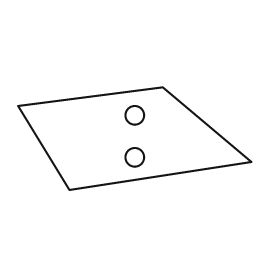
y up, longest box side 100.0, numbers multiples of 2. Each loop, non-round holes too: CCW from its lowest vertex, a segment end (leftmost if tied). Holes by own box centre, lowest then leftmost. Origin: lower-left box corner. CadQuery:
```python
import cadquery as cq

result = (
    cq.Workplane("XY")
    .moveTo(22.0, 0.0)
    .lineTo(100.0, 12.0)
    .lineTo(62.0, 44.0)
    .lineTo(0.0, 36.0)
    .close()
    .moveTo(50.0, 14.0)
    .circle(4.0)
    .moveTo(50.0, 32.0)
    .circle(4.0)
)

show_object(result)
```